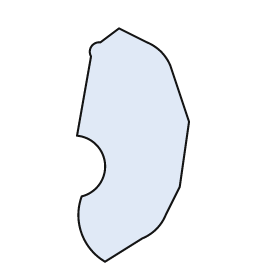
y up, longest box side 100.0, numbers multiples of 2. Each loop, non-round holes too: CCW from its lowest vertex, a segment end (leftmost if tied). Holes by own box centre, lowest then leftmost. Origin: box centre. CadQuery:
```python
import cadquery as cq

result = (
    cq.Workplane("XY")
    .moveTo(-12.0, -50.0)
    .lineTo(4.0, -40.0)
    .threePointArc((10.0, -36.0), (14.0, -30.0))
    .lineTo(20.0, -18.0)
    .lineTo(24.0, 10.0)
    .lineTo(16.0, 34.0)
    .threePointArc((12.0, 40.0), (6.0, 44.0))
    .lineTo(-6.0, 50.0)
    .lineTo(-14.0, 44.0)
    .threePointArc((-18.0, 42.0), (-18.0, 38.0))
    .lineTo(-24.0, 4.0)
    .threePointArc((-12.0, -8.0), (-22.0, -22.0))
    .threePointArc((-22.0, -38.0), (-12.0, -50.0))
    .close()
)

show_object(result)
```